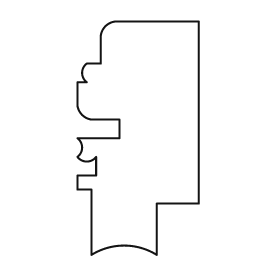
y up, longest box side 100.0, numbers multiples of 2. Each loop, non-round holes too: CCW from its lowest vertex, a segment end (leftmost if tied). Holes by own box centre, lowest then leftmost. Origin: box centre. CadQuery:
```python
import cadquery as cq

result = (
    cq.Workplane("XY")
    .moveTo(-20.0, -50.0)
    .threePointArc((-6.0, -46.0), (8.0, -50.0))
    .lineTo(8.0, -28.0)
    .lineTo(26.0, -28.0)
    .lineTo(26.0, 50.0)
    .lineTo(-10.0, 50.0)
    .threePointArc((-14.0, 48.0), (-16.0, 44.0))
    .lineTo(-16.0, 32.0)
    .lineTo(-22.0, 32.0)
    .threePointArc((-24.0, 28.0), (-22.0, 24.0))
    .lineTo(-26.0, 24.0)
    .lineTo(-26.0, 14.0)
    .threePointArc((-24.0, 10.0), (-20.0, 8.0))
    .lineTo(-8.0, 8.0)
    .lineTo(-8.0, 0.0)
    .lineTo(-26.0, 0.0)
    .threePointArc((-24.0, -4.0), (-26.0, -8.0))
    .threePointArc((-22.0, -10.0), (-18.0, -8.0))
    .lineTo(-18.0, -16.0)
    .lineTo(-26.0, -16.0)
    .lineTo(-26.0, -22.0)
    .lineTo(-20.0, -22.0)
    .close()
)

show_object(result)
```